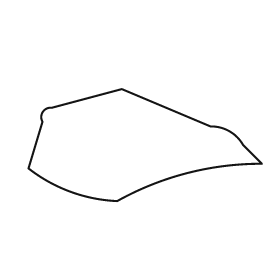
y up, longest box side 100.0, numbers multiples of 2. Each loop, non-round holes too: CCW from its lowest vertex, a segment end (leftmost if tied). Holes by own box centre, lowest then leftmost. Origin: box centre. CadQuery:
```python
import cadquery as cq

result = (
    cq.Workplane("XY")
    .moveTo(-12.0, -24.0)
    .threePointArc((18.0, -12.0), (50.0, -8.0))
    .lineTo(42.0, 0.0)
    .threePointArc((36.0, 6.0), (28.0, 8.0))
    .lineTo(-10.0, 24.0)
    .lineTo(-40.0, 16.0)
    .threePointArc((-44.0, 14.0), (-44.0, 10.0))
    .lineTo(-50.0, -10.0)
    .threePointArc((-32.0, -20.0), (-12.0, -24.0))
    .close()
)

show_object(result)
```